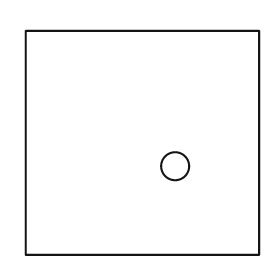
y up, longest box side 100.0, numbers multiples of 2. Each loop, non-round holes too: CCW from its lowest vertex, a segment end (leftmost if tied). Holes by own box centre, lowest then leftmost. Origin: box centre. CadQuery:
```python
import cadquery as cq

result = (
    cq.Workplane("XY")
    .moveTo(-50.0, -48.0)
    .lineTo(50.0, -48.0)
    .lineTo(50.0, 48.0)
    .lineTo(-50.0, 48.0)
    .close()
    .moveTo(14.0, -10.0)
    .circle(6.0)
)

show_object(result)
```